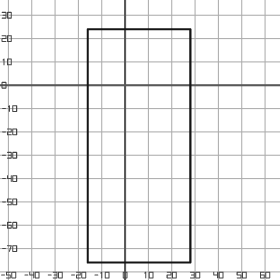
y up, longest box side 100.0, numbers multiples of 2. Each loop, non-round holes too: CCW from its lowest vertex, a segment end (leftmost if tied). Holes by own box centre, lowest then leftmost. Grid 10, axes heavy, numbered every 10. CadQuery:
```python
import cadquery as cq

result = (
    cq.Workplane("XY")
    .moveTo(-16.0, -76.0)
    .lineTo(28.0, -76.0)
    .lineTo(28.0, 24.0)
    .lineTo(-16.0, 24.0)
    .close()
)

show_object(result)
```